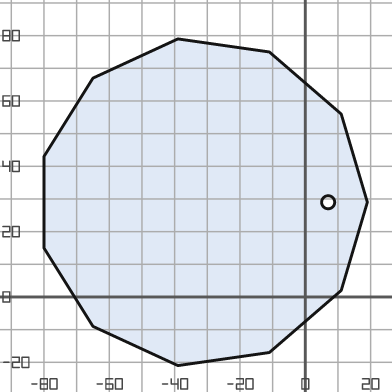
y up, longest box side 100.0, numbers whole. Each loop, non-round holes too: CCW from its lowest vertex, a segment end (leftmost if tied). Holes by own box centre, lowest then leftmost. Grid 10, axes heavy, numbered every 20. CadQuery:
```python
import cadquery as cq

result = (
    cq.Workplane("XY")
    .moveTo(-39.0, -21.0)
    .lineTo(-11.0, -17.0)
    .lineTo(11.0, 2.0)
    .lineTo(19.0, 29.0)
    .lineTo(11.0, 56.0)
    .lineTo(-11.0, 75.0)
    .lineTo(-39.0, 79.0)
    .lineTo(-65.0, 67.0)
    .lineTo(-80.0, 43.0)
    .lineTo(-80.0, 15.0)
    .lineTo(-65.0, -9.0)
    .close()
    .moveTo(7.0, 29.0)
    .circle(2.0)
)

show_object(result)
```